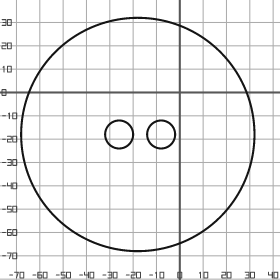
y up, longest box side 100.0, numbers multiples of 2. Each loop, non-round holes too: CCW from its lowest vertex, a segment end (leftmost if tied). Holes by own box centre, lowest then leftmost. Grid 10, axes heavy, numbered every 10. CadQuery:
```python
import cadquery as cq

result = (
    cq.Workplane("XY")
    .moveTo(-18.0, -18.0)
    .circle(50.0)
    .moveTo(-26.0, -18.0)
    .circle(6.0)
    .moveTo(-8.0, -18.0)
    .circle(6.0)
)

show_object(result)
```